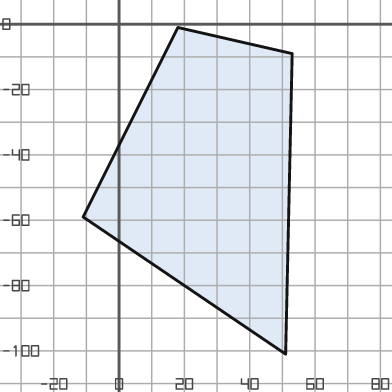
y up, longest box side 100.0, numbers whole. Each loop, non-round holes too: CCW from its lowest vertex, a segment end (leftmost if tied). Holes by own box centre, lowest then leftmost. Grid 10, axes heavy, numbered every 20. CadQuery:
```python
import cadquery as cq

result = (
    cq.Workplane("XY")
    .moveTo(51.0, -101.0)
    .lineTo(53.0, -9.0)
    .lineTo(18.0, -1.0)
    .lineTo(-11.0, -59.0)
    .close()
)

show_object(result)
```